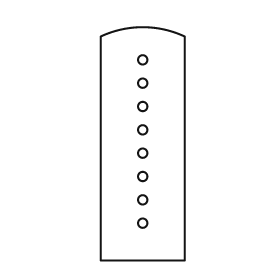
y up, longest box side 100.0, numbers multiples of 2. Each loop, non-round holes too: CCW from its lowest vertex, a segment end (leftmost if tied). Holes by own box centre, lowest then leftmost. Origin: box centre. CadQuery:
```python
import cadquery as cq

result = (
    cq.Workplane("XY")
    .moveTo(-18.0, -50.0)
    .lineTo(18.0, -50.0)
    .lineTo(18.0, 46.0)
    .threePointArc((0.0, 50.0), (-18.0, 46.0))
    .close()
    .moveTo(0.0, -34.0)
    .circle(2.0)
    .moveTo(0.0, -24.0)
    .circle(2.0)
    .moveTo(0.0, -14.0)
    .circle(2.0)
    .moveTo(0.0, -4.0)
    .circle(2.0)
    .moveTo(0.0, 6.0)
    .circle(2.0)
    .moveTo(0.0, 16.0)
    .circle(2.0)
    .moveTo(0.0, 26.0)
    .circle(2.0)
    .moveTo(0.0, 36.0)
    .circle(2.0)
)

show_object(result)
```